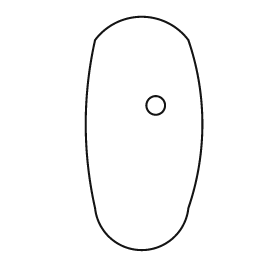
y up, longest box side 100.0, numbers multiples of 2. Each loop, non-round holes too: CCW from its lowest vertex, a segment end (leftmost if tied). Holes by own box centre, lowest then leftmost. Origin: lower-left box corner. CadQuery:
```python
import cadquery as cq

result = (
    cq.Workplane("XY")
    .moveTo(4.0, 18.0)
    .threePointArc((24.0, 0.0), (44.0, 18.0))
    .threePointArc((50.0, 54.0), (44.0, 90.0))
    .threePointArc((24.0, 100.0), (4.0, 90.0))
    .threePointArc((0.0, 54.0), (4.0, 18.0))
    .close()
    .moveTo(30.0, 62.0)
    .circle(4.0)
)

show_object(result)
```